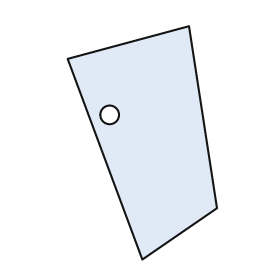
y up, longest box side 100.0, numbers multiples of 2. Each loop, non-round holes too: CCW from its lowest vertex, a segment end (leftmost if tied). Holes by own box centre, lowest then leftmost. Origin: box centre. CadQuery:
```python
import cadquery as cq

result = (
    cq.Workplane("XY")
    .moveTo(0.0, -50.0)
    .lineTo(32.0, -28.0)
    .lineTo(20.0, 50.0)
    .lineTo(-32.0, 36.0)
    .close()
    .moveTo(-14.0, 12.0)
    .circle(4.0)
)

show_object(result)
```